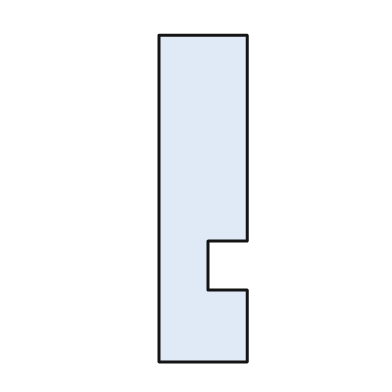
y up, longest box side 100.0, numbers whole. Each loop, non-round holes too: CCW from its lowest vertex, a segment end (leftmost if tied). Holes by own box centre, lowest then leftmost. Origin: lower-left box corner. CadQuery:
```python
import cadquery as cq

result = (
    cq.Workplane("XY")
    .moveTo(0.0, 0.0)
    .lineTo(27.0, 0.0)
    .lineTo(27.0, 22.0)
    .lineTo(15.0, 22.0)
    .lineTo(15.0, 37.0)
    .lineTo(27.0, 37.0)
    .lineTo(27.0, 100.0)
    .lineTo(0.0, 100.0)
    .close()
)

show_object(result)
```